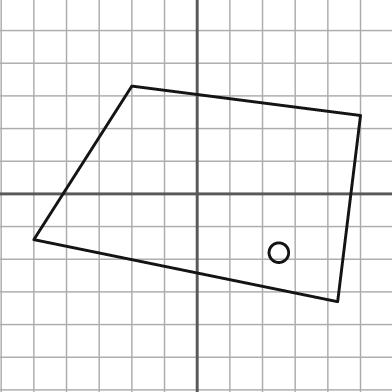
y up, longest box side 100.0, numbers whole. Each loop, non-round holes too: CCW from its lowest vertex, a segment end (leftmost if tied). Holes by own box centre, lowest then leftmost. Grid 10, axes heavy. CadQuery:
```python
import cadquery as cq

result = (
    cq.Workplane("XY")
    .moveTo(43.0, -33.0)
    .lineTo(50.0, 24.0)
    .lineTo(-20.0, 33.0)
    .lineTo(-50.0, -14.0)
    .close()
    .moveTo(25.0, -18.0)
    .circle(3.0)
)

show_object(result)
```